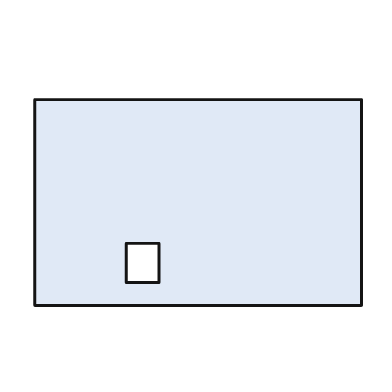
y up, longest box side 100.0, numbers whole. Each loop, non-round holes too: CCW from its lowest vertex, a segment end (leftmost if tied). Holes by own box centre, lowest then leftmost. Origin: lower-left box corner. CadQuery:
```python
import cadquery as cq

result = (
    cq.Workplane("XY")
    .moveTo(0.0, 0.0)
    .lineTo(100.0, 0.0)
    .lineTo(100.0, 63.0)
    .lineTo(0.0, 63.0)
    .close()
    .moveTo(28.0, 7.0)
    .lineTo(38.0, 7.0)
    .lineTo(38.0, 19.0)
    .lineTo(28.0, 19.0)
    .close()
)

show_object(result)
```